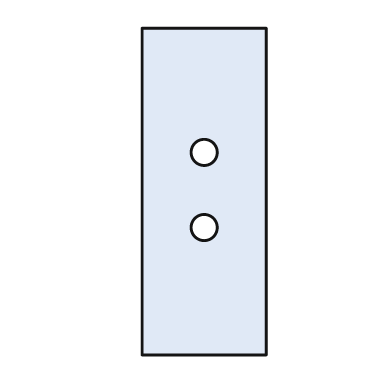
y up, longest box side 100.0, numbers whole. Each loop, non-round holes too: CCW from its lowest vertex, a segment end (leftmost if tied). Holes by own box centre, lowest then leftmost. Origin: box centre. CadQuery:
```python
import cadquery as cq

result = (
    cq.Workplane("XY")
    .moveTo(-19.0, -50.0)
    .lineTo(19.0, -50.0)
    .lineTo(19.0, 50.0)
    .lineTo(-19.0, 50.0)
    .close()
    .moveTo(0.0, -11.0)
    .circle(4.0)
    .moveTo(0.0, 12.0)
    .circle(4.0)
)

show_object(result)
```